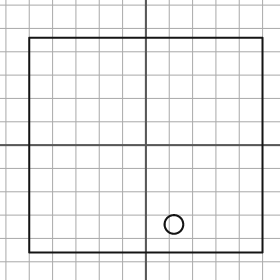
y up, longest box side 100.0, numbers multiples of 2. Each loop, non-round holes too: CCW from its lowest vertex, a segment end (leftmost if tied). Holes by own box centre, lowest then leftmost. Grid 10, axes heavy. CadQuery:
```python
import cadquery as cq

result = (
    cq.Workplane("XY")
    .moveTo(-50.0, -46.0)
    .lineTo(50.0, -46.0)
    .lineTo(50.0, 46.0)
    .lineTo(-50.0, 46.0)
    .close()
    .moveTo(12.0, -34.0)
    .circle(4.0)
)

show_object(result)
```